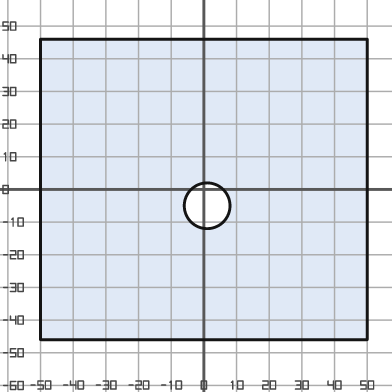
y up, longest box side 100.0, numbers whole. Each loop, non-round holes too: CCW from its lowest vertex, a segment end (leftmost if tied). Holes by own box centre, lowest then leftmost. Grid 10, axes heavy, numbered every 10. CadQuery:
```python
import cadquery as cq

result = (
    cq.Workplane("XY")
    .moveTo(-50.0, -46.0)
    .lineTo(50.0, -46.0)
    .lineTo(50.0, 46.0)
    .lineTo(-50.0, 46.0)
    .close()
    .moveTo(1.0, -5.0)
    .circle(7.0)
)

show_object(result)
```